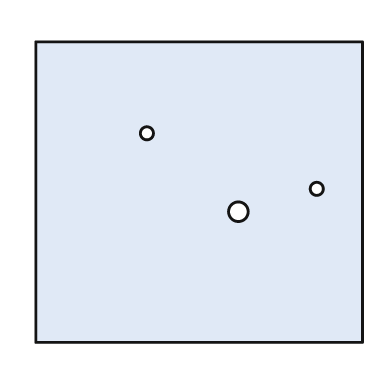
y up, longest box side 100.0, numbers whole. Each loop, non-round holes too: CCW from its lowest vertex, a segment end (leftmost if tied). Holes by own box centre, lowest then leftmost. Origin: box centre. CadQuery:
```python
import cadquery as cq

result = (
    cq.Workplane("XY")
    .moveTo(-50.0, -46.0)
    .lineTo(50.0, -46.0)
    .lineTo(50.0, 46.0)
    .lineTo(-50.0, 46.0)
    .close()
    .moveTo(12.0, -6.0)
    .circle(3.0)
    .moveTo(36.0, 1.0)
    .circle(2.0)
    .moveTo(-16.0, 18.0)
    .circle(2.0)
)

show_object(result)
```